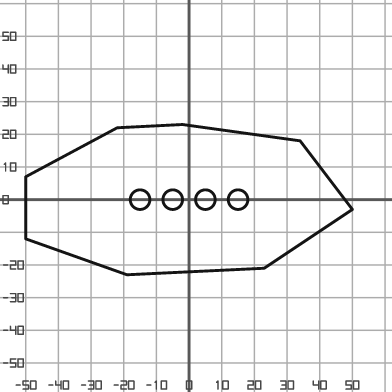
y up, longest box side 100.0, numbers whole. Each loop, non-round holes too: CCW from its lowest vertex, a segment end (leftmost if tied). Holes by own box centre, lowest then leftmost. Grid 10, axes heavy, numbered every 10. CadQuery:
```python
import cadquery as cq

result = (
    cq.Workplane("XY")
    .moveTo(-19.0, -23.0)
    .lineTo(23.0, -21.0)
    .lineTo(50.0, -3.0)
    .lineTo(34.0, 18.0)
    .lineTo(-2.0, 23.0)
    .lineTo(-22.0, 22.0)
    .lineTo(-50.0, 7.0)
    .lineTo(-50.0, -12.0)
    .close()
    .moveTo(-15.0, 0.0)
    .circle(3.0)
    .moveTo(-5.0, 0.0)
    .circle(3.0)
    .moveTo(5.0, 0.0)
    .circle(3.0)
    .moveTo(15.0, 0.0)
    .circle(3.0)
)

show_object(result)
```